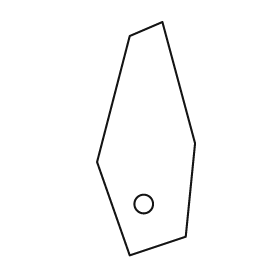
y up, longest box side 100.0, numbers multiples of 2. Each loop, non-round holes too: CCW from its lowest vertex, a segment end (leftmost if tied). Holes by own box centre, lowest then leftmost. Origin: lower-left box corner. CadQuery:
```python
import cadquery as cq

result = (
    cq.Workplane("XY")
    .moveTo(14.0, 0.0)
    .lineTo(38.0, 8.0)
    .lineTo(42.0, 48.0)
    .lineTo(28.0, 100.0)
    .lineTo(14.0, 94.0)
    .lineTo(0.0, 40.0)
    .close()
    .moveTo(20.0, 22.0)
    .circle(4.0)
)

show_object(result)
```